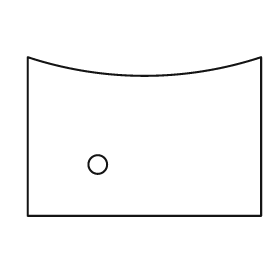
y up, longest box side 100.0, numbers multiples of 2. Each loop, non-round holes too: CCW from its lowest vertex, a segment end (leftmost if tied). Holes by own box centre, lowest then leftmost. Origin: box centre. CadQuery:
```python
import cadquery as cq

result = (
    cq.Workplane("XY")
    .moveTo(-50.0, -34.0)
    .lineTo(50.0, -34.0)
    .lineTo(50.0, 34.0)
    .threePointArc((0.0, 26.0), (-50.0, 34.0))
    .close()
    .moveTo(-20.0, -12.0)
    .circle(4.0)
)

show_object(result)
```